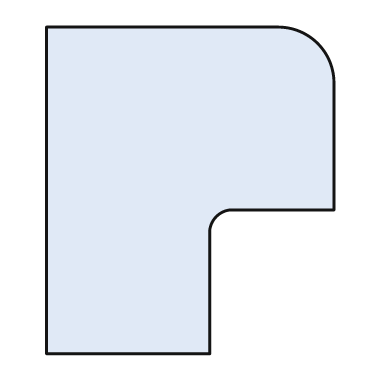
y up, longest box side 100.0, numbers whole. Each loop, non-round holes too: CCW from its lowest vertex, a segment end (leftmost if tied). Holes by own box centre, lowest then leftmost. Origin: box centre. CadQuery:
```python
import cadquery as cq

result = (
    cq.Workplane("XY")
    .moveTo(-44.0, -50.0)
    .lineTo(6.0, -50.0)
    .lineTo(6.0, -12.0)
    .threePointArc((8.0, -8.0), (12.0, -6.0))
    .lineTo(44.0, -6.0)
    .lineTo(44.0, 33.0)
    .threePointArc((39.0, 45.0), (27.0, 50.0))
    .lineTo(-44.0, 50.0)
    .close()
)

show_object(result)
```